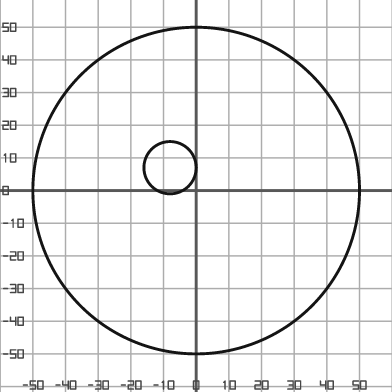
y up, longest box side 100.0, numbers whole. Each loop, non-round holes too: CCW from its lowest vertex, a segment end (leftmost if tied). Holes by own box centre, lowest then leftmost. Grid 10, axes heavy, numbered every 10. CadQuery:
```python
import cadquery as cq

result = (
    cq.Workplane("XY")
    .moveTo(0.0, 0.0)
    .circle(50.0)
    .moveTo(-8.0, 7.0)
    .circle(8.0)
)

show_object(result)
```